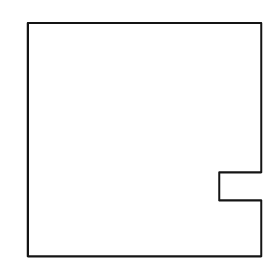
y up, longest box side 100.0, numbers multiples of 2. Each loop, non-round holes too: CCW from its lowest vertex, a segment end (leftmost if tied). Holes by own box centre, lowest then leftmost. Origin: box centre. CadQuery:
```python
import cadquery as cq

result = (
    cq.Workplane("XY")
    .moveTo(-50.0, -50.0)
    .lineTo(50.0, -50.0)
    .lineTo(50.0, -26.0)
    .lineTo(32.0, -26.0)
    .lineTo(32.0, -14.0)
    .lineTo(50.0, -14.0)
    .lineTo(50.0, 50.0)
    .lineTo(-50.0, 50.0)
    .close()
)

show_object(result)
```